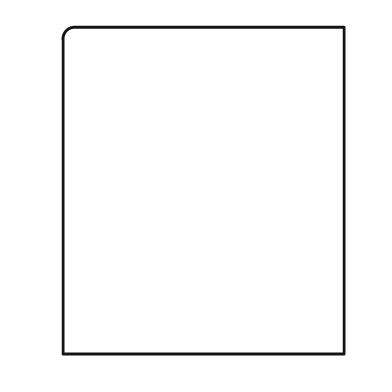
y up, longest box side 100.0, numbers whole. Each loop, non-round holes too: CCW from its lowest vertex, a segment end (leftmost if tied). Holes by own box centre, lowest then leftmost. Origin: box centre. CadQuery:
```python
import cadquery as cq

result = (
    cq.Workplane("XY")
    .moveTo(-43.0, -50.0)
    .lineTo(43.0, -50.0)
    .lineTo(43.0, 50.0)
    .lineTo(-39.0, 50.0)
    .threePointArc((-42.0, 49.0), (-43.0, 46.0))
    .close()
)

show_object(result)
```